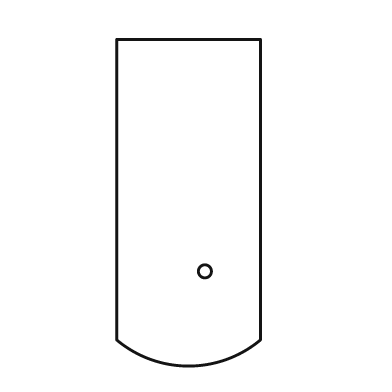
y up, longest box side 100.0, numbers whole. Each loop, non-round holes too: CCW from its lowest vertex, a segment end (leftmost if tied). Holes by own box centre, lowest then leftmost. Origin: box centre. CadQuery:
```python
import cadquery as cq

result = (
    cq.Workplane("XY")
    .moveTo(-22.0, -42.0)
    .threePointArc((0.0, -50.0), (22.0, -42.0))
    .lineTo(22.0, 50.0)
    .lineTo(-22.0, 50.0)
    .close()
    .moveTo(5.0, -21.0)
    .circle(2.0)
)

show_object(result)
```